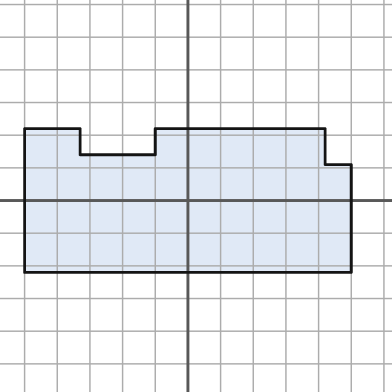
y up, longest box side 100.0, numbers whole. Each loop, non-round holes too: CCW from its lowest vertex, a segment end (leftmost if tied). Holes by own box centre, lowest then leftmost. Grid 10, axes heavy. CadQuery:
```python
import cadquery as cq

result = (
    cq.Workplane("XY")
    .moveTo(-50.0, -22.0)
    .lineTo(50.0, -22.0)
    .lineTo(50.0, 11.0)
    .lineTo(42.0, 11.0)
    .lineTo(42.0, 22.0)
    .lineTo(-10.0, 22.0)
    .lineTo(-10.0, 14.0)
    .lineTo(-33.0, 14.0)
    .lineTo(-33.0, 22.0)
    .lineTo(-50.0, 22.0)
    .close()
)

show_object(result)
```